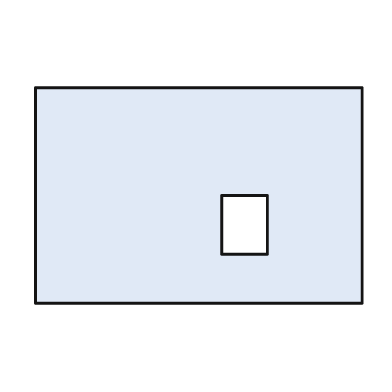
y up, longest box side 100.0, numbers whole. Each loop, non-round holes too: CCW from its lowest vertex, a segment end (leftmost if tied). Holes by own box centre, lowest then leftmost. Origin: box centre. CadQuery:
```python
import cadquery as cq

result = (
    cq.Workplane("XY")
    .moveTo(-50.0, -33.0)
    .lineTo(50.0, -33.0)
    .lineTo(50.0, 33.0)
    .lineTo(-50.0, 33.0)
    .close()
    .moveTo(7.0, -18.0)
    .lineTo(21.0, -18.0)
    .lineTo(21.0, 0.0)
    .lineTo(7.0, 0.0)
    .close()
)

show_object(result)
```